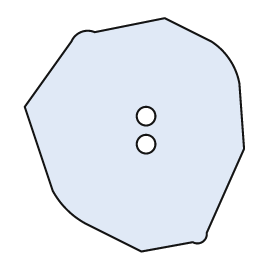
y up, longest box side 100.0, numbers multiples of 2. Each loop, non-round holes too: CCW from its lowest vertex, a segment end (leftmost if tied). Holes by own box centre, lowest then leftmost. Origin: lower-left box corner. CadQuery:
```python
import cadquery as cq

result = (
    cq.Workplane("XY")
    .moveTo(50.0, 0.0)
    .lineTo(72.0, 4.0)
    .threePointArc((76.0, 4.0), (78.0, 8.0))
    .lineTo(94.0, 44.0)
    .lineTo(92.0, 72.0)
    .threePointArc((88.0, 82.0), (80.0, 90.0))
    .lineTo(60.0, 100.0)
    .lineTo(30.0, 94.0)
    .threePointArc((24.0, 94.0), (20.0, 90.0))
    .lineTo(0.0, 62.0)
    .lineTo(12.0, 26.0)
    .threePointArc((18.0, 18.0), (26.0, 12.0))
    .close()
    .moveTo(52.0, 46.0)
    .circle(4.0)
    .moveTo(52.0, 58.0)
    .circle(4.0)
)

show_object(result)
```